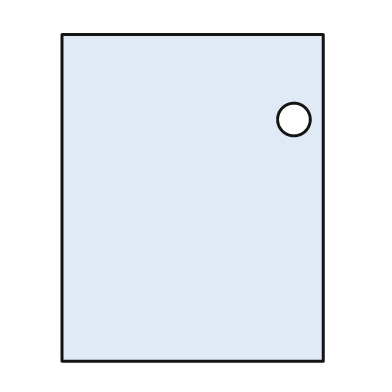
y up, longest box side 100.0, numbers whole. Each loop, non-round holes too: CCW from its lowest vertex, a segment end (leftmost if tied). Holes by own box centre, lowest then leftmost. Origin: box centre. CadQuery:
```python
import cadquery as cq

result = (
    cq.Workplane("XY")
    .moveTo(-40.0, -50.0)
    .lineTo(40.0, -50.0)
    .lineTo(40.0, 50.0)
    .lineTo(-40.0, 50.0)
    .close()
    .moveTo(31.0, 24.0)
    .circle(5.0)
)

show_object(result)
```